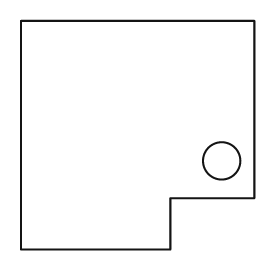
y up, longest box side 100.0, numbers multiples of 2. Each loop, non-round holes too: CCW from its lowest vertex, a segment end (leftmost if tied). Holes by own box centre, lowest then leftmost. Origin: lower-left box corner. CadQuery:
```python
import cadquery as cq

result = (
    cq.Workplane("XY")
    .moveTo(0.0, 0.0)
    .lineTo(64.0, 0.0)
    .lineTo(64.0, 22.0)
    .lineTo(100.0, 22.0)
    .lineTo(100.0, 98.0)
    .lineTo(0.0, 98.0)
    .close()
    .moveTo(86.0, 38.0)
    .circle(8.0)
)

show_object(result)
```